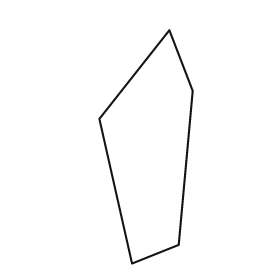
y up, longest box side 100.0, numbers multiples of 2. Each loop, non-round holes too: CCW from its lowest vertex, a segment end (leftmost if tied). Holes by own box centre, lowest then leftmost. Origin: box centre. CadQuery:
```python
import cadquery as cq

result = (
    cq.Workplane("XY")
    .moveTo(-6.0, -50.0)
    .lineTo(14.0, -42.0)
    .lineTo(20.0, 24.0)
    .lineTo(10.0, 50.0)
    .lineTo(-20.0, 12.0)
    .close()
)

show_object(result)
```